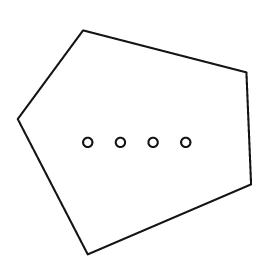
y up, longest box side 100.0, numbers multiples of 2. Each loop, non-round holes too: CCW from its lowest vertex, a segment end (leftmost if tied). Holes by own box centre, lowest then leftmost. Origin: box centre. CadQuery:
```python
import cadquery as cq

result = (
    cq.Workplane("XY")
    .moveTo(-20.0, -48.0)
    .lineTo(50.0, -18.0)
    .lineTo(48.0, 30.0)
    .lineTo(-22.0, 48.0)
    .lineTo(-50.0, 10.0)
    .close()
    .moveTo(-20.0, 0.0)
    .circle(2.0)
    .moveTo(-6.0, 0.0)
    .circle(2.0)
    .moveTo(8.0, 0.0)
    .circle(2.0)
    .moveTo(22.0, 0.0)
    .circle(2.0)
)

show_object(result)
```